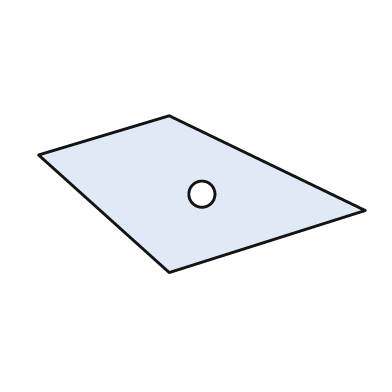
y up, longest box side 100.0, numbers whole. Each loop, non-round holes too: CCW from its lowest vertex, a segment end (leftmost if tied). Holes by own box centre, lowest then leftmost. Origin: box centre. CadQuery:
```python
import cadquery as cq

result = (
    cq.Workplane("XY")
    .moveTo(-10.0, -24.0)
    .lineTo(50.0, -5.0)
    .lineTo(-10.0, 24.0)
    .lineTo(-50.0, 12.0)
    .close()
    .moveTo(0.0, 0.0)
    .circle(4.0)
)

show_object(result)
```